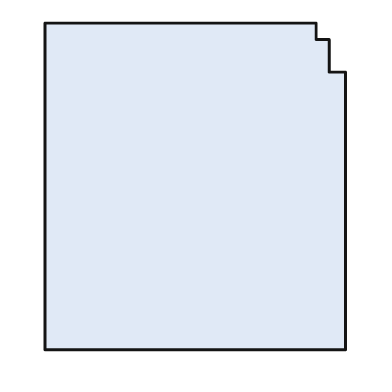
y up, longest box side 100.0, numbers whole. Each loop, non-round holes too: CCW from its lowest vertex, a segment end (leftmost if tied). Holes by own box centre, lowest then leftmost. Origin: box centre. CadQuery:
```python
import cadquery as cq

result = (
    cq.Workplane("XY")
    .moveTo(-46.0, -50.0)
    .lineTo(46.0, -50.0)
    .lineTo(46.0, 35.0)
    .lineTo(41.0, 35.0)
    .lineTo(41.0, 45.0)
    .lineTo(37.0, 45.0)
    .lineTo(37.0, 50.0)
    .lineTo(-46.0, 50.0)
    .close()
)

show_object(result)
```